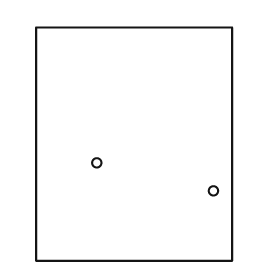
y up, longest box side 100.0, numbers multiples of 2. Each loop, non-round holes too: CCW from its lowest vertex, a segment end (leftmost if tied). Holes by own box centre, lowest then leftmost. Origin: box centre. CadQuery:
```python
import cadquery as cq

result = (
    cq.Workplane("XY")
    .moveTo(-42.0, -50.0)
    .lineTo(42.0, -50.0)
    .lineTo(42.0, 50.0)
    .lineTo(-42.0, 50.0)
    .close()
    .moveTo(34.0, -20.0)
    .circle(2.0)
    .moveTo(-16.0, -8.0)
    .circle(2.0)
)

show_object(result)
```